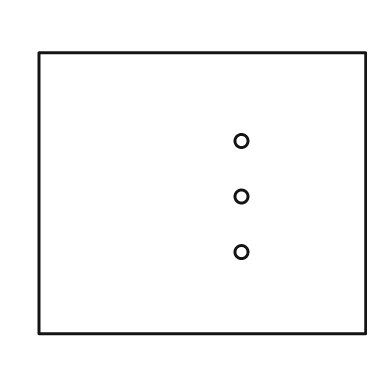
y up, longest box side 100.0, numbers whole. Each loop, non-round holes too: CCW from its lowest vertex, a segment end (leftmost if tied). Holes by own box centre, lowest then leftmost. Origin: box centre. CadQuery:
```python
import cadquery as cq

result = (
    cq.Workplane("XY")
    .moveTo(-50.0, -43.0)
    .lineTo(50.0, -43.0)
    .lineTo(50.0, 43.0)
    .lineTo(-50.0, 43.0)
    .close()
    .moveTo(12.0, -18.0)
    .circle(2.0)
    .moveTo(12.0, -1.0)
    .circle(2.0)
    .moveTo(12.0, 16.0)
    .circle(2.0)
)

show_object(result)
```